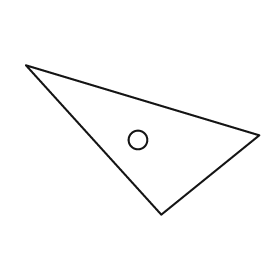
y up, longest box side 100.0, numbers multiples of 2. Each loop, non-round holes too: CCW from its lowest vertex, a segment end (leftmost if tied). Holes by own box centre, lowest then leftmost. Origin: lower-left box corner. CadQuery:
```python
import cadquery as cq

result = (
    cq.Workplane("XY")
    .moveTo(58.0, 0.0)
    .lineTo(100.0, 34.0)
    .lineTo(0.0, 64.0)
    .close()
    .moveTo(48.0, 32.0)
    .circle(4.0)
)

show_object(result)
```